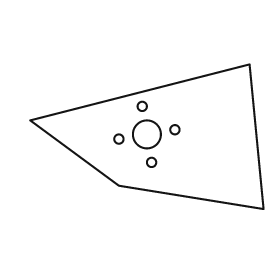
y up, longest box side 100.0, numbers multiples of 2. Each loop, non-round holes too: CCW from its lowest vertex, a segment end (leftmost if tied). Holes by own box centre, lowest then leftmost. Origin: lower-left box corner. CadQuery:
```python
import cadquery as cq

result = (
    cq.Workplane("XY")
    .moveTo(100.0, 0.0)
    .lineTo(94.0, 62.0)
    .lineTo(0.0, 38.0)
    .lineTo(38.0, 10.0)
    .close()
    .moveTo(52.0, 20.0)
    .circle(2.0)
    .moveTo(38.0, 30.0)
    .circle(2.0)
    .moveTo(50.0, 32.0)
    .circle(6.0)
    .moveTo(62.0, 34.0)
    .circle(2.0)
    .moveTo(48.0, 44.0)
    .circle(2.0)
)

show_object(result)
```